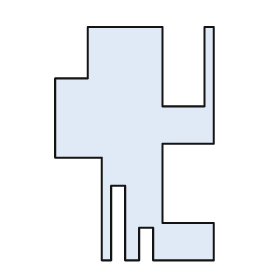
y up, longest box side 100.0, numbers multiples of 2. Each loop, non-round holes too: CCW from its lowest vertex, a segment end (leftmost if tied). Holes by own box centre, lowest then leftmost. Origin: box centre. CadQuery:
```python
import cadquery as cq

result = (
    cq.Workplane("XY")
    .moveTo(-14.0, -50.0)
    .lineTo(-10.0, -50.0)
    .lineTo(-10.0, -18.0)
    .lineTo(-4.0, -18.0)
    .lineTo(-4.0, -50.0)
    .lineTo(2.0, -50.0)
    .lineTo(2.0, -36.0)
    .lineTo(8.0, -36.0)
    .lineTo(8.0, -50.0)
    .lineTo(34.0, -50.0)
    .lineTo(34.0, -34.0)
    .lineTo(12.0, -34.0)
    .lineTo(12.0, 0.0)
    .lineTo(34.0, 0.0)
    .lineTo(34.0, 50.0)
    .lineTo(30.0, 50.0)
    .lineTo(30.0, 16.0)
    .lineTo(12.0, 16.0)
    .lineTo(12.0, 50.0)
    .lineTo(-20.0, 50.0)
    .lineTo(-20.0, 28.0)
    .lineTo(-34.0, 28.0)
    .lineTo(-34.0, -6.0)
    .lineTo(-14.0, -6.0)
    .close()
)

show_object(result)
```